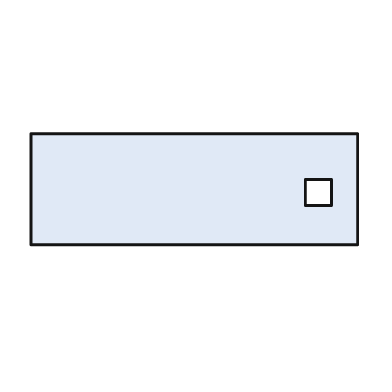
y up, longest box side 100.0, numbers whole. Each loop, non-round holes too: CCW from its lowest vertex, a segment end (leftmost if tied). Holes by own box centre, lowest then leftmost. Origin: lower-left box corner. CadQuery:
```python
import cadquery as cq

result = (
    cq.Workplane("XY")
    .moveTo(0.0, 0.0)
    .lineTo(100.0, 0.0)
    .lineTo(100.0, 34.0)
    .lineTo(0.0, 34.0)
    .close()
    .moveTo(84.0, 12.0)
    .lineTo(92.0, 12.0)
    .lineTo(92.0, 20.0)
    .lineTo(84.0, 20.0)
    .close()
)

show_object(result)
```